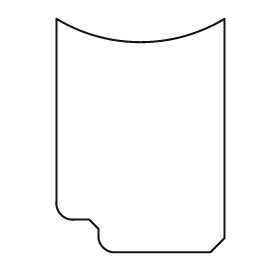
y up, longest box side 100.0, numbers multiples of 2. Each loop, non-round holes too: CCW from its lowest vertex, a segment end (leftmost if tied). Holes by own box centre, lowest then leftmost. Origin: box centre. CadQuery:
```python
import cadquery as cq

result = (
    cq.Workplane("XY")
    .moveTo(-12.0, -50.0)
    .lineTo(30.0, -50.0)
    .lineTo(36.0, -44.0)
    .lineTo(36.0, 50.0)
    .threePointArc((0.0, 40.0), (-36.0, 50.0))
    .lineTo(-36.0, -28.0)
    .threePointArc((-34.0, -34.0), (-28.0, -36.0))
    .lineTo(-22.0, -36.0)
    .lineTo(-18.0, -40.0)
    .lineTo(-18.0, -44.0)
    .threePointArc((-16.0, -48.0), (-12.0, -50.0))
    .close()
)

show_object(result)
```